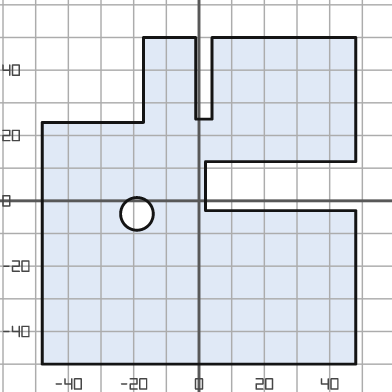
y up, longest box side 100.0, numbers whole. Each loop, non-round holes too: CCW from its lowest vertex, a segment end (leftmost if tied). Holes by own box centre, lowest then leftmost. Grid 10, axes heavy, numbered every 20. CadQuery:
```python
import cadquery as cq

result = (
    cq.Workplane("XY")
    .moveTo(-48.0, -50.0)
    .lineTo(48.0, -50.0)
    .lineTo(48.0, -3.0)
    .lineTo(2.0, -3.0)
    .lineTo(2.0, 12.0)
    .lineTo(48.0, 12.0)
    .lineTo(48.0, 50.0)
    .lineTo(4.0, 50.0)
    .lineTo(4.0, 25.0)
    .lineTo(-1.0, 25.0)
    .lineTo(-1.0, 50.0)
    .lineTo(-17.0, 50.0)
    .lineTo(-17.0, 24.0)
    .lineTo(-48.0, 24.0)
    .close()
    .moveTo(-19.0, -4.0)
    .circle(5.0)
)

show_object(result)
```